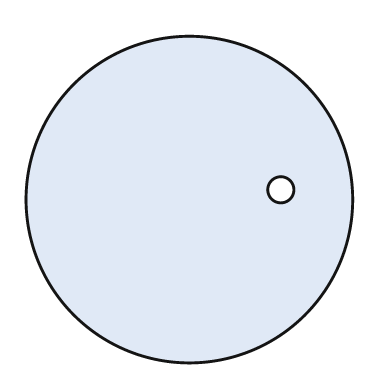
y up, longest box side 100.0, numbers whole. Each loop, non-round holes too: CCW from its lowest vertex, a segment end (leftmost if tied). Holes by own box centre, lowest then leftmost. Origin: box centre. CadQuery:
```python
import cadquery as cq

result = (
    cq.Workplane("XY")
    .moveTo(0.0, 0.0)
    .circle(50.0)
    .moveTo(28.0, 3.0)
    .circle(4.0)
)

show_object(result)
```